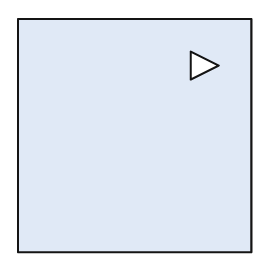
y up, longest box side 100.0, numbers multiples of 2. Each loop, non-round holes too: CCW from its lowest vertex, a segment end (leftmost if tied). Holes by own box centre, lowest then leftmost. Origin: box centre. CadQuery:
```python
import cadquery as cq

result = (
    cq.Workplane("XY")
    .moveTo(-50.0, -50.0)
    .lineTo(50.0, -50.0)
    .lineTo(50.0, 50.0)
    .lineTo(-50.0, 50.0)
    .close()
    .moveTo(24.0, 24.0)
    .lineTo(36.0, 30.0)
    .lineTo(24.0, 36.0)
    .close()
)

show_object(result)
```